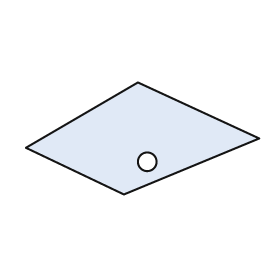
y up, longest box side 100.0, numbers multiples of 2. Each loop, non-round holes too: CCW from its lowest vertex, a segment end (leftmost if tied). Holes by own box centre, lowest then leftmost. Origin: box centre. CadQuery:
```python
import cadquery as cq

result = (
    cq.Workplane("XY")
    .moveTo(-8.0, -24.0)
    .lineTo(50.0, 0.0)
    .lineTo(-2.0, 24.0)
    .lineTo(-50.0, -4.0)
    .close()
    .moveTo(2.0, -10.0)
    .circle(4.0)
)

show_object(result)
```